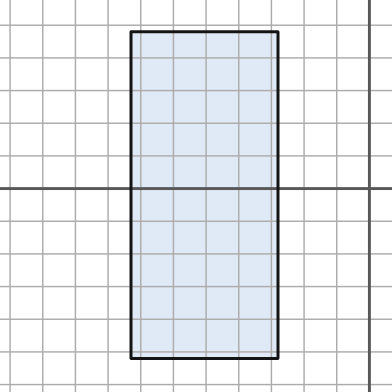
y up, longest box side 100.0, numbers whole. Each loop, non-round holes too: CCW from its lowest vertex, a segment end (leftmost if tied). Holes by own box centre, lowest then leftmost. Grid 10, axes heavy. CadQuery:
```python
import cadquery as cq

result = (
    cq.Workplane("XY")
    .moveTo(-73.0, -52.0)
    .lineTo(-28.0, -52.0)
    .lineTo(-28.0, 48.0)
    .lineTo(-73.0, 48.0)
    .close()
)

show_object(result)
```